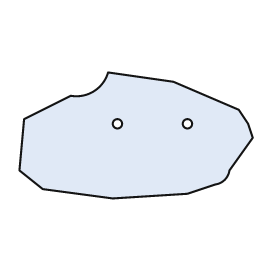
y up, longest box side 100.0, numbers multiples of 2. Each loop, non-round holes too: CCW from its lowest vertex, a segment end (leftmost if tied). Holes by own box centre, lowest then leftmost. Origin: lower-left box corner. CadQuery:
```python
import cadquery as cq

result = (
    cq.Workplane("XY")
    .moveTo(40.0, 0.0)
    .lineTo(72.0, 2.0)
    .lineTo(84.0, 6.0)
    .threePointArc((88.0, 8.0), (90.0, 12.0))
    .lineTo(100.0, 26.0)
    .lineTo(98.0, 32.0)
    .lineTo(94.0, 38.0)
    .lineTo(66.0, 50.0)
    .lineTo(38.0, 54.0)
    .threePointArc((32.0, 46.0), (22.0, 44.0))
    .lineTo(2.0, 34.0)
    .lineTo(0.0, 12.0)
    .lineTo(10.0, 4.0)
    .close()
    .moveTo(42.0, 32.0)
    .circle(2.0)
    .moveTo(72.0, 32.0)
    .circle(2.0)
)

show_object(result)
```